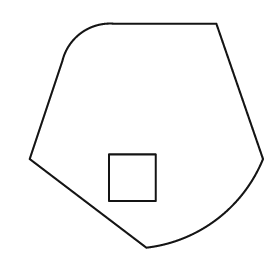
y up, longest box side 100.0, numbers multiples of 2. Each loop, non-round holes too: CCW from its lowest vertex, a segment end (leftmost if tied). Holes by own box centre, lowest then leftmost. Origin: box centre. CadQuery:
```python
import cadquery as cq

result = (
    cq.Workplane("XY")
    .moveTo(0.0, -48.0)
    .threePointArc((30.0, -36.0), (50.0, -10.0))
    .lineTo(30.0, 48.0)
    .lineTo(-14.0, 48.0)
    .threePointArc((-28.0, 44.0), (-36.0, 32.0))
    .lineTo(-50.0, -10.0)
    .close()
    .moveTo(-16.0, -28.0)
    .lineTo(4.0, -28.0)
    .lineTo(4.0, -8.0)
    .lineTo(-16.0, -8.0)
    .close()
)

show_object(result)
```